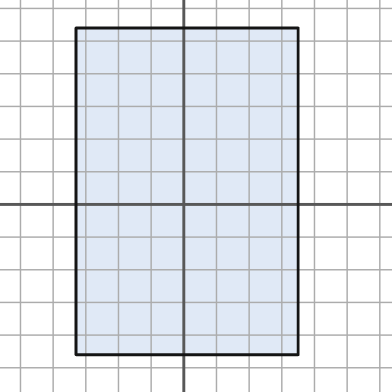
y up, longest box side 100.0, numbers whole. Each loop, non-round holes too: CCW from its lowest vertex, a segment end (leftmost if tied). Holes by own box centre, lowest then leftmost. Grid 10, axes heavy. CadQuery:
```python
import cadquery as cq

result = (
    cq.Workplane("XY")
    .moveTo(-33.0, -46.0)
    .lineTo(35.0, -46.0)
    .lineTo(35.0, 54.0)
    .lineTo(-33.0, 54.0)
    .close()
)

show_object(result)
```